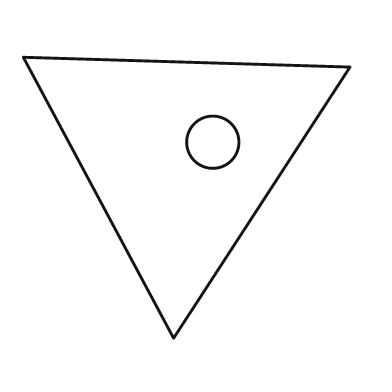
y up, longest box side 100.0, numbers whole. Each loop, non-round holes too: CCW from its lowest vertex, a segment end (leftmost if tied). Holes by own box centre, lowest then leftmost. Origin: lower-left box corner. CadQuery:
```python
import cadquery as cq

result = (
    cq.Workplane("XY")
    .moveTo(46.0, 0.0)
    .lineTo(100.0, 83.0)
    .lineTo(0.0, 86.0)
    .close()
    .moveTo(58.0, 60.0)
    .circle(8.0)
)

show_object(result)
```